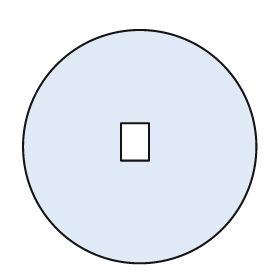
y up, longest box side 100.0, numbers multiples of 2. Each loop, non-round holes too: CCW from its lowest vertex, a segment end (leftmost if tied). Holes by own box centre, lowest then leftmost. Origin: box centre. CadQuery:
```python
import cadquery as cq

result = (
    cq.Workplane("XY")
    .moveTo(0.0, 0.0)
    .circle(50.0)
    .moveTo(-8.0, -6.0)
    .lineTo(4.0, -6.0)
    .lineTo(4.0, 10.0)
    .lineTo(-8.0, 10.0)
    .close()
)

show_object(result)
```